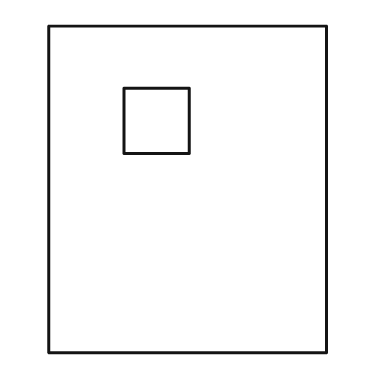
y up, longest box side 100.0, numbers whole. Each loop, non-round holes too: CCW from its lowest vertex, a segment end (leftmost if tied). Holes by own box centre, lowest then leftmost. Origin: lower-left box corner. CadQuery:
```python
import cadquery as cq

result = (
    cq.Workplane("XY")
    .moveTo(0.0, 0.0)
    .lineTo(85.0, 0.0)
    .lineTo(85.0, 100.0)
    .lineTo(0.0, 100.0)
    .close()
    .moveTo(23.0, 61.0)
    .lineTo(43.0, 61.0)
    .lineTo(43.0, 81.0)
    .lineTo(23.0, 81.0)
    .close()
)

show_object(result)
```